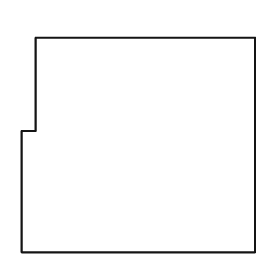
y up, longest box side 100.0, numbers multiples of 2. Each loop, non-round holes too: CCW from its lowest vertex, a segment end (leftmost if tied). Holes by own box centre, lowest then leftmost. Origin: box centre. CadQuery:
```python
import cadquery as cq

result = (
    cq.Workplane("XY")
    .moveTo(-50.0, -46.0)
    .lineTo(50.0, -46.0)
    .lineTo(50.0, 46.0)
    .lineTo(-44.0, 46.0)
    .lineTo(-44.0, 6.0)
    .lineTo(-50.0, 6.0)
    .close()
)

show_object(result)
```